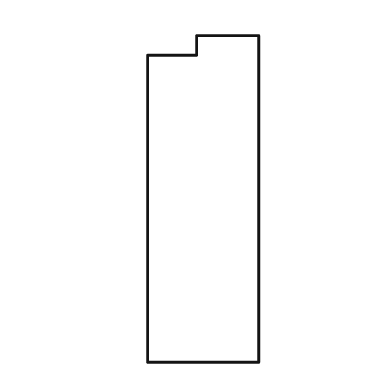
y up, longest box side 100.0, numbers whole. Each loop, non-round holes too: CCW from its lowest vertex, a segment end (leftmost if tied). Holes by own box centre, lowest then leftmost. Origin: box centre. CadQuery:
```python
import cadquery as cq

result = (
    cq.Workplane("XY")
    .moveTo(-17.0, -50.0)
    .lineTo(17.0, -50.0)
    .lineTo(17.0, 50.0)
    .lineTo(-2.0, 50.0)
    .lineTo(-2.0, 44.0)
    .lineTo(-17.0, 44.0)
    .close()
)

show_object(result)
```